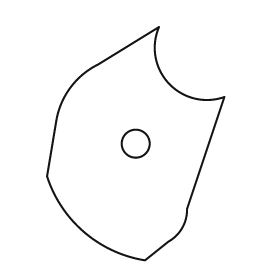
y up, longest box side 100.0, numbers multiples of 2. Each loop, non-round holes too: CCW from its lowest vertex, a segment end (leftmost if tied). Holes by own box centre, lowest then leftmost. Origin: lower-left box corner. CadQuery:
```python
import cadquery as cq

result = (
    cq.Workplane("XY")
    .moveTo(42.0, 0.0)
    .lineTo(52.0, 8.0)
    .threePointArc((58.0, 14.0), (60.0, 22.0))
    .lineTo(76.0, 70.0)
    .threePointArc((52.0, 76.0), (48.0, 100.0))
    .lineTo(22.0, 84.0)
    .threePointArc((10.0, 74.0), (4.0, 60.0))
    .lineTo(0.0, 36.0)
    .threePointArc((16.0, 12.0), (42.0, 0.0))
    .close()
    .moveTo(38.0, 50.0)
    .circle(6.0)
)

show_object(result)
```